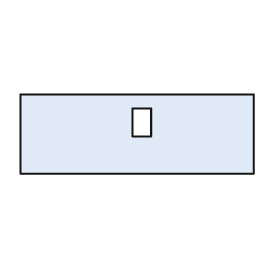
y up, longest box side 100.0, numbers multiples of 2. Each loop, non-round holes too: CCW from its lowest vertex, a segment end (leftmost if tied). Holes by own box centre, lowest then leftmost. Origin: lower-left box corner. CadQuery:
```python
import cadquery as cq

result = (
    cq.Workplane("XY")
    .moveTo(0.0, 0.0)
    .lineTo(100.0, 0.0)
    .lineTo(100.0, 34.0)
    .lineTo(0.0, 34.0)
    .close()
    .moveTo(48.0, 16.0)
    .lineTo(56.0, 16.0)
    .lineTo(56.0, 28.0)
    .lineTo(48.0, 28.0)
    .close()
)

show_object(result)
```